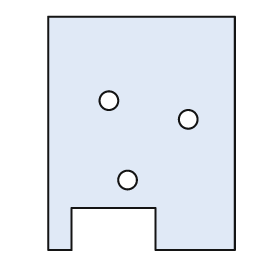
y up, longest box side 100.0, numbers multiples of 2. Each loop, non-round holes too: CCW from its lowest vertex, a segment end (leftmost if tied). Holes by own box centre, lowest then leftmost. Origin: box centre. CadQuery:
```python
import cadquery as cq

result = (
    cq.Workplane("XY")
    .moveTo(-40.0, -50.0)
    .lineTo(-30.0, -50.0)
    .lineTo(-30.0, -32.0)
    .lineTo(6.0, -32.0)
    .lineTo(6.0, -50.0)
    .lineTo(40.0, -50.0)
    .lineTo(40.0, 50.0)
    .lineTo(-40.0, 50.0)
    .close()
    .moveTo(-6.0, -20.0)
    .circle(4.0)
    .moveTo(20.0, 6.0)
    .circle(4.0)
    .moveTo(-14.0, 14.0)
    .circle(4.0)
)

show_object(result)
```